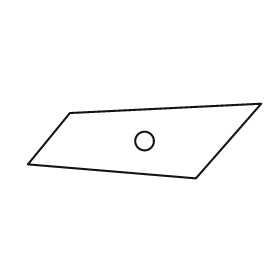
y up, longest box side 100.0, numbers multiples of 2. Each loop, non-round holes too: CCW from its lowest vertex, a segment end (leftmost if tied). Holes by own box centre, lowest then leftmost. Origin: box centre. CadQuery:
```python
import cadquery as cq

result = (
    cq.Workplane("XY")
    .moveTo(22.0, -16.0)
    .lineTo(50.0, 16.0)
    .lineTo(-32.0, 12.0)
    .lineTo(-50.0, -10.0)
    .close()
    .moveTo(0.0, 0.0)
    .circle(4.0)
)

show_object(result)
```